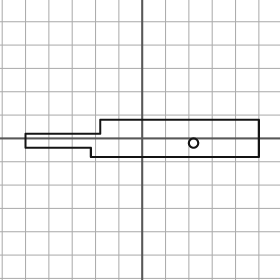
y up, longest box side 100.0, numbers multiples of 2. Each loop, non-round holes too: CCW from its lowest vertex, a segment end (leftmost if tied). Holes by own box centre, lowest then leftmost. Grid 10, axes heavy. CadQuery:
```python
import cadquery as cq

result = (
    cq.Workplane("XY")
    .moveTo(-22.0, -8.0)
    .lineTo(50.0, -8.0)
    .lineTo(50.0, 8.0)
    .lineTo(-18.0, 8.0)
    .lineTo(-18.0, 2.0)
    .lineTo(-50.0, 2.0)
    .lineTo(-50.0, -4.0)
    .lineTo(-22.0, -4.0)
    .close()
    .moveTo(22.0, -2.0)
    .circle(2.0)
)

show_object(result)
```